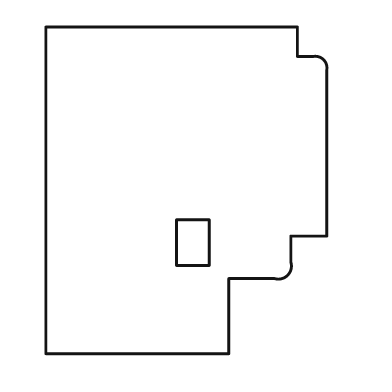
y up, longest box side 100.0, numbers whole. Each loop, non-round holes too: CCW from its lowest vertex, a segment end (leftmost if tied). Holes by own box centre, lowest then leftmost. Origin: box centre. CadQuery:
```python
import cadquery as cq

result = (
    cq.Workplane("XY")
    .moveTo(-43.0, -50.0)
    .lineTo(13.0, -50.0)
    .lineTo(13.0, -27.0)
    .lineTo(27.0, -27.0)
    .threePointArc((31.0, -26.0), (32.0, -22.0))
    .lineTo(32.0, -14.0)
    .lineTo(43.0, -14.0)
    .lineTo(43.0, 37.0)
    .threePointArc((42.0, 40.0), (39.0, 41.0))
    .lineTo(34.0, 41.0)
    .lineTo(34.0, 50.0)
    .lineTo(-43.0, 50.0)
    .close()
    .moveTo(-3.0, -23.0)
    .lineTo(7.0, -23.0)
    .lineTo(7.0, -9.0)
    .lineTo(-3.0, -9.0)
    .close()
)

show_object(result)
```